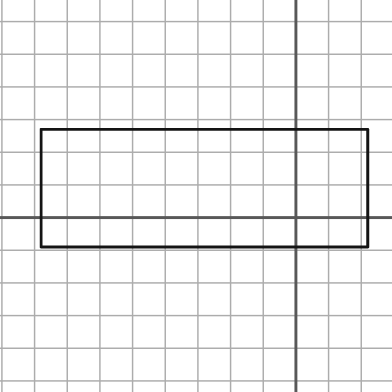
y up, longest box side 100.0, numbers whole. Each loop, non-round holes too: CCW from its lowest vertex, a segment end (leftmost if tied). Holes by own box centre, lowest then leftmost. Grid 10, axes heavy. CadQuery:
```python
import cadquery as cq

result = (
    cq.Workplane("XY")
    .moveTo(-78.0, -9.0)
    .lineTo(22.0, -9.0)
    .lineTo(22.0, 27.0)
    .lineTo(-78.0, 27.0)
    .close()
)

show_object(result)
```